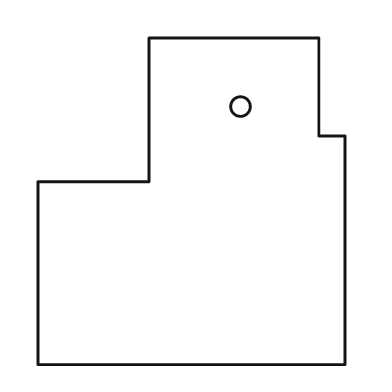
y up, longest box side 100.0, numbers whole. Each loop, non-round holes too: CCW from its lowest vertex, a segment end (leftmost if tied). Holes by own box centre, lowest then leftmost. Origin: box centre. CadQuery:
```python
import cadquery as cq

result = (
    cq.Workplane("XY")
    .moveTo(-47.0, -50.0)
    .lineTo(47.0, -50.0)
    .lineTo(47.0, 20.0)
    .lineTo(39.0, 20.0)
    .lineTo(39.0, 50.0)
    .lineTo(-13.0, 50.0)
    .lineTo(-13.0, 6.0)
    .lineTo(-47.0, 6.0)
    .close()
    .moveTo(15.0, 29.0)
    .circle(3.0)
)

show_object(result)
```